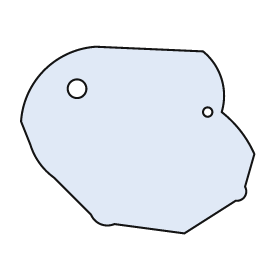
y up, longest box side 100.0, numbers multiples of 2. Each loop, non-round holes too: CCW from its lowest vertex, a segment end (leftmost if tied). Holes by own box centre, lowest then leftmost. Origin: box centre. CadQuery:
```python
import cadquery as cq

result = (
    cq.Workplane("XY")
    .moveTo(20.0, -40.0)
    .lineTo(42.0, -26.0)
    .threePointArc((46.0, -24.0), (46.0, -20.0))
    .lineTo(50.0, -6.0)
    .threePointArc((44.0, 4.0), (36.0, 12.0))
    .threePointArc((36.0, 26.0), (28.0, 38.0))
    .lineTo(-18.0, 40.0)
    .threePointArc((-40.0, 30.0), (-50.0, 8.0))
    .lineTo(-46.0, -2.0)
    .threePointArc((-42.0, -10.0), (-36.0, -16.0))
    .lineTo(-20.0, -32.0)
    .threePointArc((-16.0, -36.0), (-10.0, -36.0))
    .close()
    .moveTo(30.0, 12.0)
    .circle(2.0)
    .moveTo(-26.0, 22.0)
    .circle(4.0)
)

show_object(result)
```